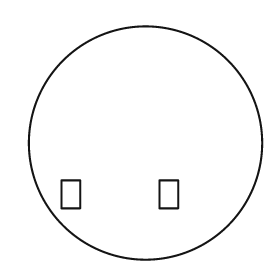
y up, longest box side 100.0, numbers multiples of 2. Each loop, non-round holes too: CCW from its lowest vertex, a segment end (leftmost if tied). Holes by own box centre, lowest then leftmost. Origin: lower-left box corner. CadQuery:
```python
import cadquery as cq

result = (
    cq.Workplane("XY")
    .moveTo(50.0, 50.0)
    .circle(50.0)
    .moveTo(14.0, 22.0)
    .lineTo(22.0, 22.0)
    .lineTo(22.0, 34.0)
    .lineTo(14.0, 34.0)
    .close()
    .moveTo(56.0, 22.0)
    .lineTo(64.0, 22.0)
    .lineTo(64.0, 34.0)
    .lineTo(56.0, 34.0)
    .close()
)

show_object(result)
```